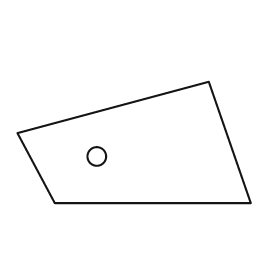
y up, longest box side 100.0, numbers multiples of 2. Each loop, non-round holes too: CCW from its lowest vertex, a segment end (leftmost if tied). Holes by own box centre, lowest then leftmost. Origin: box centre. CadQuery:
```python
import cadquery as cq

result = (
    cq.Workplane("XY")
    .moveTo(-34.0, -26.0)
    .lineTo(50.0, -26.0)
    .lineTo(32.0, 26.0)
    .lineTo(-50.0, 4.0)
    .close()
    .moveTo(-16.0, -6.0)
    .circle(4.0)
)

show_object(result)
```